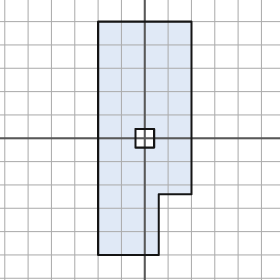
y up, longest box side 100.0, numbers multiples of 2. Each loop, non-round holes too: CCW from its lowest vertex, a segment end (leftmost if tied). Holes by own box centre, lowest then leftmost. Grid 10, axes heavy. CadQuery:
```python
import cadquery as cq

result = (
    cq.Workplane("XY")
    .moveTo(-20.0, -50.0)
    .lineTo(6.0, -50.0)
    .lineTo(6.0, -24.0)
    .lineTo(20.0, -24.0)
    .lineTo(20.0, 50.0)
    .lineTo(-20.0, 50.0)
    .close()
    .moveTo(-4.0, -4.0)
    .lineTo(4.0, -4.0)
    .lineTo(4.0, 4.0)
    .lineTo(-4.0, 4.0)
    .close()
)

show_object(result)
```